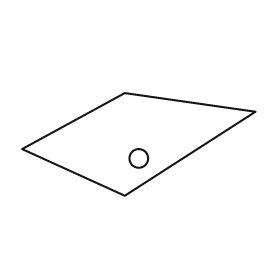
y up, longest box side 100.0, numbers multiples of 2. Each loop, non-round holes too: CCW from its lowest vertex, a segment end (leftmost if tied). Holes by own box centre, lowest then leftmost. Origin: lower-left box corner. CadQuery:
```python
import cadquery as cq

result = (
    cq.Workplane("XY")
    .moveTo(44.0, 0.0)
    .lineTo(100.0, 36.0)
    .lineTo(44.0, 44.0)
    .lineTo(0.0, 20.0)
    .close()
    .moveTo(50.0, 16.0)
    .circle(4.0)
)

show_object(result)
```